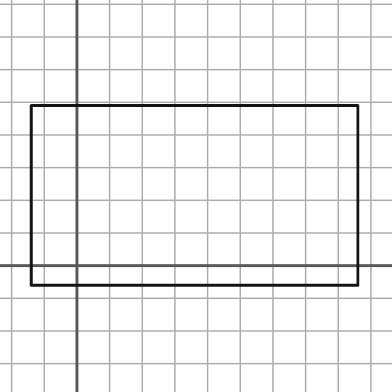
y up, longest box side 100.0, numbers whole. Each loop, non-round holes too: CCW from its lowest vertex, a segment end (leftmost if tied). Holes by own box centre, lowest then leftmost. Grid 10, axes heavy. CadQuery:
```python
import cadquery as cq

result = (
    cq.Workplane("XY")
    .moveTo(-14.0, -6.0)
    .lineTo(86.0, -6.0)
    .lineTo(86.0, 49.0)
    .lineTo(-14.0, 49.0)
    .close()
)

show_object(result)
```